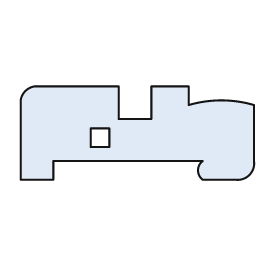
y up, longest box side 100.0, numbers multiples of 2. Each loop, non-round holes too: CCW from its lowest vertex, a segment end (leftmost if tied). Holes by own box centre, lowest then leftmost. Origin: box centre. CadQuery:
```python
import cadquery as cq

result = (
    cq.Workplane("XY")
    .moveTo(-50.0, -20.0)
    .lineTo(-36.0, -20.0)
    .lineTo(-36.0, -12.0)
    .lineTo(28.0, -12.0)
    .threePointArc((26.0, -16.0), (28.0, -20.0))
    .lineTo(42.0, -20.0)
    .threePointArc((48.0, -18.0), (50.0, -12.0))
    .lineTo(50.0, 12.0)
    .threePointArc((36.0, 14.0), (22.0, 12.0))
    .lineTo(22.0, 20.0)
    .lineTo(6.0, 20.0)
    .lineTo(6.0, 6.0)
    .lineTo(-8.0, 6.0)
    .lineTo(-8.0, 20.0)
    .lineTo(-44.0, 20.0)
    .threePointArc((-48.0, 18.0), (-50.0, 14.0))
    .close()
    .moveTo(-20.0, -6.0)
    .lineTo(-12.0, -6.0)
    .lineTo(-12.0, 2.0)
    .lineTo(-20.0, 2.0)
    .close()
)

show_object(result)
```